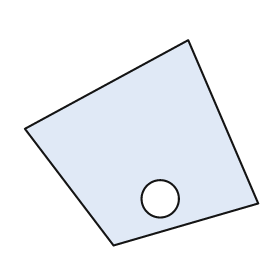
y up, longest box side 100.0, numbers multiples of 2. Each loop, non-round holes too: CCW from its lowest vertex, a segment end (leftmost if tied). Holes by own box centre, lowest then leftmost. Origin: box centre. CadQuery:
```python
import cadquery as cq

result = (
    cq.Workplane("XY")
    .moveTo(-12.0, -44.0)
    .lineTo(50.0, -26.0)
    .lineTo(20.0, 44.0)
    .lineTo(-50.0, 6.0)
    .close()
    .moveTo(8.0, -24.0)
    .circle(8.0)
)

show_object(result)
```